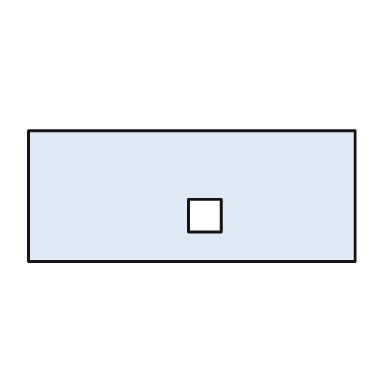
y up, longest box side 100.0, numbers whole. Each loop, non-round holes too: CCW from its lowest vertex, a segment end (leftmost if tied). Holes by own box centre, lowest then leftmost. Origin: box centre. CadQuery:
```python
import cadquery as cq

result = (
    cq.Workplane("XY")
    .moveTo(-50.0, -20.0)
    .lineTo(50.0, -20.0)
    .lineTo(50.0, 20.0)
    .lineTo(-50.0, 20.0)
    .close()
    .moveTo(-1.0, -11.0)
    .lineTo(9.0, -11.0)
    .lineTo(9.0, -1.0)
    .lineTo(-1.0, -1.0)
    .close()
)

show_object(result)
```